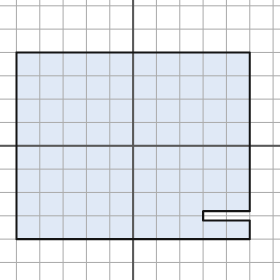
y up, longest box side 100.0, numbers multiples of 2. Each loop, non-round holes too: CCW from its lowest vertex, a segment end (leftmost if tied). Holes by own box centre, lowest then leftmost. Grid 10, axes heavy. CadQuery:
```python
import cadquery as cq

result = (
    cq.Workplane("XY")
    .moveTo(-50.0, -40.0)
    .lineTo(50.0, -40.0)
    .lineTo(50.0, -32.0)
    .lineTo(30.0, -32.0)
    .lineTo(30.0, -28.0)
    .lineTo(50.0, -28.0)
    .lineTo(50.0, 40.0)
    .lineTo(-50.0, 40.0)
    .close()
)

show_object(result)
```